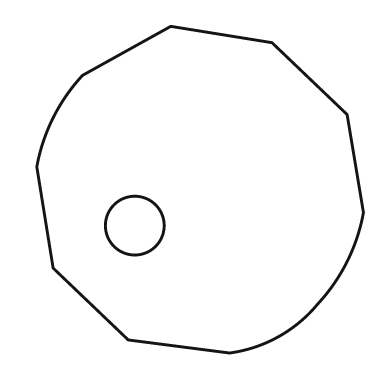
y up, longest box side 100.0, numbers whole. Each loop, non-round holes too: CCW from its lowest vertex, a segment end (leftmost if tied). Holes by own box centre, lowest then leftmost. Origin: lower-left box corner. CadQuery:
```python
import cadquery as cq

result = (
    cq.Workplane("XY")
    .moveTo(59.0, 0.0)
    .threePointArc((74.0, 5.0), (86.0, 15.0))
    .threePointArc((95.0, 28.0), (100.0, 43.0))
    .lineTo(95.0, 73.0)
    .lineTo(72.0, 95.0)
    .lineTo(41.0, 100.0)
    .lineTo(14.0, 85.0)
    .threePointArc((5.0, 72.0), (0.0, 57.0))
    .lineTo(5.0, 26.0)
    .lineTo(28.0, 4.0)
    .close()
    .moveTo(30.0, 39.0)
    .circle(9.0)
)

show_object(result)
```